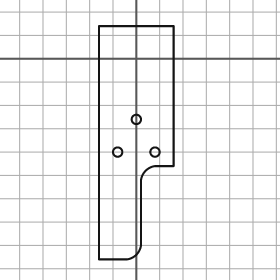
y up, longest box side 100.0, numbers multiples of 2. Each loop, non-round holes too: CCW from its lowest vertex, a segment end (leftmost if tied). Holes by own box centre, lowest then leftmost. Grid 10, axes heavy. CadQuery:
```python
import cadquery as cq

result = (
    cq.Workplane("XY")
    .moveTo(-16.0, -86.0)
    .lineTo(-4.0, -86.0)
    .threePointArc((0.0, -84.0), (2.0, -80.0))
    .lineTo(2.0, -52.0)
    .threePointArc((4.0, -48.0), (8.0, -46.0))
    .lineTo(16.0, -46.0)
    .lineTo(16.0, 14.0)
    .lineTo(-16.0, 14.0)
    .close()
    .moveTo(-8.0, -40.0)
    .circle(2.0)
    .moveTo(8.0, -40.0)
    .circle(2.0)
    .moveTo(0.0, -26.0)
    .circle(2.0)
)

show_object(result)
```